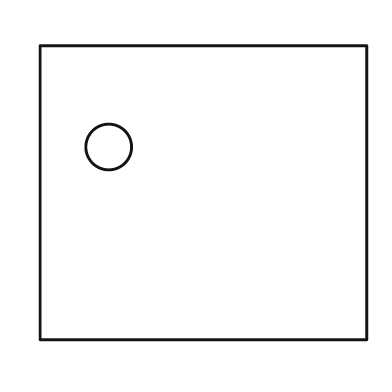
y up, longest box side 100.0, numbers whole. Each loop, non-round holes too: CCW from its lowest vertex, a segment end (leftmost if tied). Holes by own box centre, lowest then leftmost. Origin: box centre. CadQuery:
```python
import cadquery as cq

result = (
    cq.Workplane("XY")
    .moveTo(-50.0, -45.0)
    .lineTo(50.0, -45.0)
    .lineTo(50.0, 45.0)
    .lineTo(-50.0, 45.0)
    .close()
    .moveTo(-29.0, 14.0)
    .circle(7.0)
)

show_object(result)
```